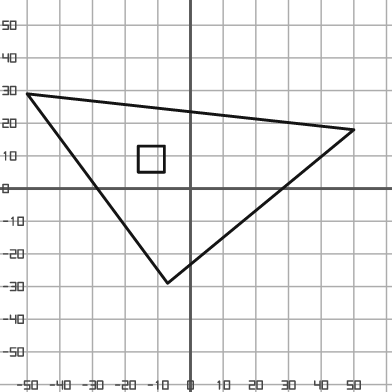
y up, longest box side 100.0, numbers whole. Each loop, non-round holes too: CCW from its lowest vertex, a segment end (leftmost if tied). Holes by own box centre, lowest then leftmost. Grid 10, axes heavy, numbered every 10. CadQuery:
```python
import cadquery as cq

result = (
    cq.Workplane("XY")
    .moveTo(-7.0, -29.0)
    .lineTo(50.0, 18.0)
    .lineTo(-50.0, 29.0)
    .close()
    .moveTo(-16.0, 5.0)
    .lineTo(-8.0, 5.0)
    .lineTo(-8.0, 13.0)
    .lineTo(-16.0, 13.0)
    .close()
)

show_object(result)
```